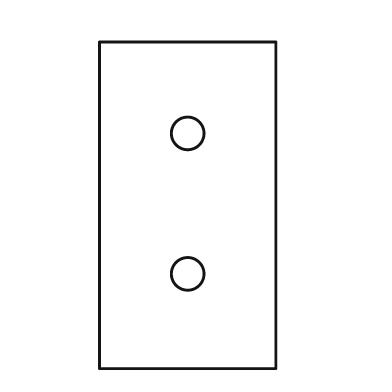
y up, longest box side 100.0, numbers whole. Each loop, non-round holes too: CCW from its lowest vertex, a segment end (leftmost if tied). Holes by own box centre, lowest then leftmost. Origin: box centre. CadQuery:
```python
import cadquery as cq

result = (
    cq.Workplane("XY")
    .moveTo(-27.0, -50.0)
    .lineTo(27.0, -50.0)
    .lineTo(27.0, 50.0)
    .lineTo(-27.0, 50.0)
    .close()
    .moveTo(0.0, -21.0)
    .circle(5.0)
    .moveTo(0.0, 22.0)
    .circle(5.0)
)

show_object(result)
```